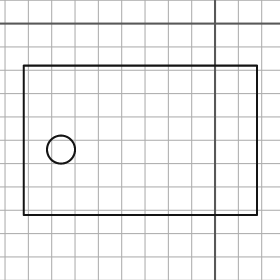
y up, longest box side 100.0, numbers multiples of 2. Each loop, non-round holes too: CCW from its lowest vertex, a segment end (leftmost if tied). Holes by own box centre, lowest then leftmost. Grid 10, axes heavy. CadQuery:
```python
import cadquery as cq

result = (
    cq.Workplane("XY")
    .moveTo(-82.0, -82.0)
    .lineTo(18.0, -82.0)
    .lineTo(18.0, -18.0)
    .lineTo(-82.0, -18.0)
    .close()
    .moveTo(-66.0, -54.0)
    .circle(6.0)
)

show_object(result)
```